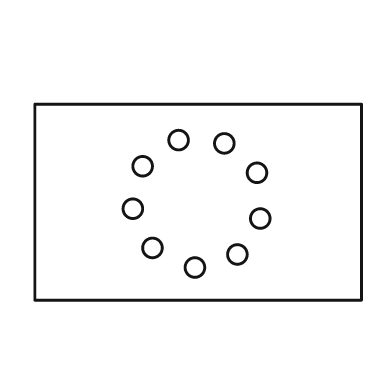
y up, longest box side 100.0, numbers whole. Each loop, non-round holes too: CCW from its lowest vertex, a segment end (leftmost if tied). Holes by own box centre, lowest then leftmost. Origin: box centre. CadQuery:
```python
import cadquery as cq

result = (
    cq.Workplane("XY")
    .moveTo(-50.0, -30.0)
    .lineTo(50.0, -30.0)
    .lineTo(50.0, 30.0)
    .lineTo(-50.0, 30.0)
    .close()
    .moveTo(-1.0, -20.0)
    .circle(3.0)
    .moveTo(12.0, -16.0)
    .circle(3.0)
    .moveTo(-14.0, -14.0)
    .circle(3.0)
    .moveTo(19.0, -5.0)
    .circle(3.0)
    .moveTo(-20.0, -2.0)
    .circle(3.0)
    .moveTo(18.0, 9.0)
    .circle(3.0)
    .moveTo(-17.0, 11.0)
    .circle(3.0)
    .moveTo(8.0, 18.0)
    .circle(3.0)
    .moveTo(-6.0, 19.0)
    .circle(3.0)
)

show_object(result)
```